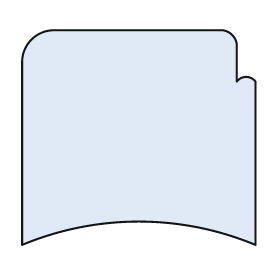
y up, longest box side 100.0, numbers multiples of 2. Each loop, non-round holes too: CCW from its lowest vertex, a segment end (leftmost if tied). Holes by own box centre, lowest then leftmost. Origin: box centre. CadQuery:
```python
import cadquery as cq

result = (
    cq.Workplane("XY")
    .moveTo(-50.0, -46.0)
    .threePointArc((0.0, -36.0), (50.0, -46.0))
    .lineTo(50.0, 24.0)
    .threePointArc((46.0, 26.0), (42.0, 24.0))
    .lineTo(42.0, 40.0)
    .threePointArc((40.0, 44.0), (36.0, 46.0))
    .lineTo(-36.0, 46.0)
    .threePointArc((-46.0, 42.0), (-50.0, 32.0))
    .close()
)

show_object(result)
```